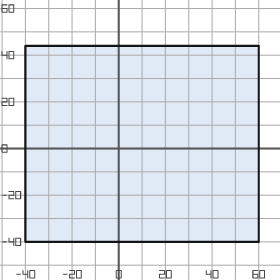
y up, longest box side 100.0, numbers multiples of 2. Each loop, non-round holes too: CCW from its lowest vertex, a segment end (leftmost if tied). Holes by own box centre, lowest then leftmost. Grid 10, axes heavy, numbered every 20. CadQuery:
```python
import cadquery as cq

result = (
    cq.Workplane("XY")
    .moveTo(-40.0, -40.0)
    .lineTo(60.0, -40.0)
    .lineTo(60.0, 44.0)
    .lineTo(-40.0, 44.0)
    .close()
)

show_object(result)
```